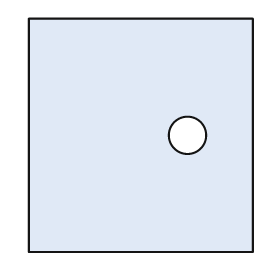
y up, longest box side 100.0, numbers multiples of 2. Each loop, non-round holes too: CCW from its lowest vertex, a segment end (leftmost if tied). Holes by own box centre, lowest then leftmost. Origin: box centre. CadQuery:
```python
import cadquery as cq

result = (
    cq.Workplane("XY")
    .moveTo(-48.0, -50.0)
    .lineTo(48.0, -50.0)
    .lineTo(48.0, 50.0)
    .lineTo(-48.0, 50.0)
    .close()
    .moveTo(20.0, 0.0)
    .circle(8.0)
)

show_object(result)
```